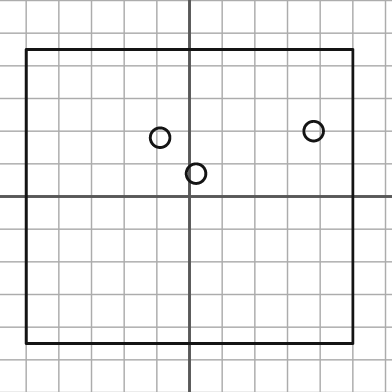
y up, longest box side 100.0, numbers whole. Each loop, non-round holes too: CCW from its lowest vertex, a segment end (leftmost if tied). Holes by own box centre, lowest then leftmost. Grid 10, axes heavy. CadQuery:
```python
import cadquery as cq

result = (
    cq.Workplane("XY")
    .moveTo(-50.0, -45.0)
    .lineTo(50.0, -45.0)
    .lineTo(50.0, 45.0)
    .lineTo(-50.0, 45.0)
    .close()
    .moveTo(2.0, 7.0)
    .circle(3.0)
    .moveTo(-9.0, 18.0)
    .circle(3.0)
    .moveTo(38.0, 20.0)
    .circle(3.0)
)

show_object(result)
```